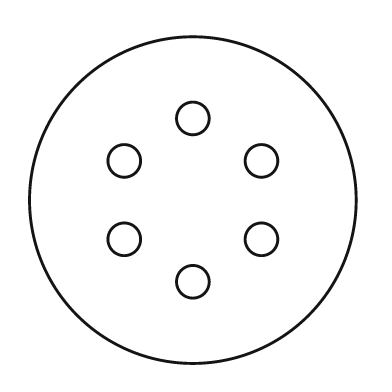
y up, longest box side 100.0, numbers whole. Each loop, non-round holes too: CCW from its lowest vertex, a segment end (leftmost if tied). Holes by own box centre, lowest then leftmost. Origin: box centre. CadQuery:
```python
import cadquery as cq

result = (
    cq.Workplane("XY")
    .moveTo(0.0, 0.0)
    .circle(50.0)
    .moveTo(0.0, -25.0)
    .circle(5.0)
    .moveTo(-21.0, -12.0)
    .circle(5.0)
    .moveTo(21.0, -12.0)
    .circle(5.0)
    .moveTo(-21.0, 12.0)
    .circle(5.0)
    .moveTo(21.0, 12.0)
    .circle(5.0)
    .moveTo(0.0, 25.0)
    .circle(5.0)
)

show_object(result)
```